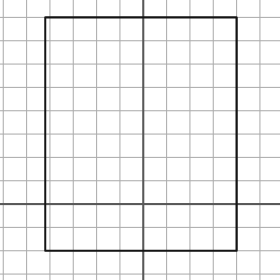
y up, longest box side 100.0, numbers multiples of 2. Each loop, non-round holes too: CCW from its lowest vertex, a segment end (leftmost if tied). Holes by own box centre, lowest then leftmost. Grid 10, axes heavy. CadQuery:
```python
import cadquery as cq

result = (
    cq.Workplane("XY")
    .moveTo(-42.0, -20.0)
    .lineTo(40.0, -20.0)
    .lineTo(40.0, 80.0)
    .lineTo(-42.0, 80.0)
    .close()
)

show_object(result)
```